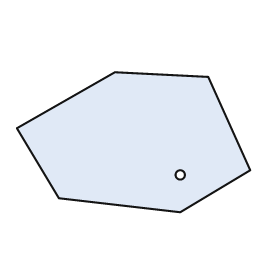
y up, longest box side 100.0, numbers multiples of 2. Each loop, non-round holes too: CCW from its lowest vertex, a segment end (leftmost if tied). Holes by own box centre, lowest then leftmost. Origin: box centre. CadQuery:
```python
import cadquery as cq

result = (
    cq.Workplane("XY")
    .moveTo(20.0, -30.0)
    .lineTo(50.0, -12.0)
    .lineTo(32.0, 28.0)
    .lineTo(-8.0, 30.0)
    .lineTo(-50.0, 6.0)
    .lineTo(-32.0, -24.0)
    .close()
    .moveTo(20.0, -14.0)
    .circle(2.0)
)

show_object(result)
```